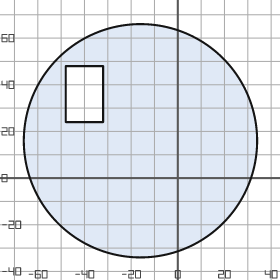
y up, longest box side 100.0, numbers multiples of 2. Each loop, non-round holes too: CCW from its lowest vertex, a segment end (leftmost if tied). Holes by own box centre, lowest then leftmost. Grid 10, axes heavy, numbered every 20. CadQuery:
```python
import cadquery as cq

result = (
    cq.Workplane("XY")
    .moveTo(-16.0, 16.0)
    .circle(50.0)
    .moveTo(-48.0, 24.0)
    .lineTo(-32.0, 24.0)
    .lineTo(-32.0, 48.0)
    .lineTo(-48.0, 48.0)
    .close()
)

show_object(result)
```